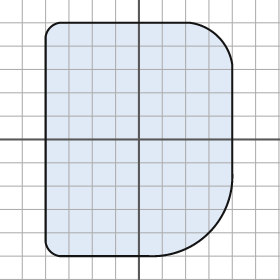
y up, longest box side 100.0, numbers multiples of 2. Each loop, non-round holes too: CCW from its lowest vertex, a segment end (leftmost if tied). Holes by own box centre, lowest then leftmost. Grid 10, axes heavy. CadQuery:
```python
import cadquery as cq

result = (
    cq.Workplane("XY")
    .moveTo(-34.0, -50.0)
    .lineTo(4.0, -50.0)
    .threePointArc((30.0, -40.0), (40.0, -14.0))
    .lineTo(40.0, 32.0)
    .threePointArc((34.0, 44.0), (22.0, 50.0))
    .lineTo(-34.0, 50.0)
    .threePointArc((-38.0, 48.0), (-40.0, 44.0))
    .lineTo(-40.0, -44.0)
    .threePointArc((-38.0, -48.0), (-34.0, -50.0))
    .close()
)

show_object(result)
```